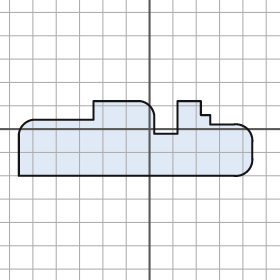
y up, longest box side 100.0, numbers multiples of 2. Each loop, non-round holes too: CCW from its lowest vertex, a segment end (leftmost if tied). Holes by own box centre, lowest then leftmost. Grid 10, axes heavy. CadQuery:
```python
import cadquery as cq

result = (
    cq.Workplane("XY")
    .moveTo(-56.0, -20.0)
    .lineTo(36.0, -20.0)
    .threePointArc((42.0, -18.0), (44.0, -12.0))
    .lineTo(44.0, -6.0)
    .threePointArc((42.0, 0.0), (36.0, 2.0))
    .lineTo(26.0, 2.0)
    .lineTo(26.0, 6.0)
    .lineTo(22.0, 6.0)
    .lineTo(22.0, 12.0)
    .lineTo(12.0, 12.0)
    .lineTo(12.0, -2.0)
    .lineTo(2.0, -2.0)
    .lineTo(2.0, 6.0)
    .threePointArc((0.0, 10.0), (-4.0, 12.0))
    .lineTo(-24.0, 12.0)
    .lineTo(-24.0, 4.0)
    .lineTo(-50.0, 4.0)
    .threePointArc((-54.0, 2.0), (-56.0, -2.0))
    .close()
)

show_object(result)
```